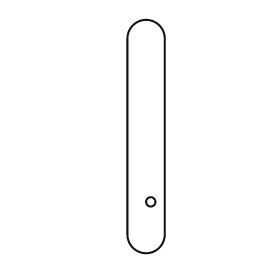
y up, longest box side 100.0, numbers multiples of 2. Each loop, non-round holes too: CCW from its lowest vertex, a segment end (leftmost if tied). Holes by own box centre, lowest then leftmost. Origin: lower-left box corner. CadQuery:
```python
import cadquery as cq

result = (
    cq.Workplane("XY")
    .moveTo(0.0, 8.0)
    .threePointArc((8.0, 0.0), (16.0, 8.0))
    .lineTo(16.0, 92.0)
    .threePointArc((8.0, 100.0), (0.0, 92.0))
    .close()
    .moveTo(10.0, 22.0)
    .circle(2.0)
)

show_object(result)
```